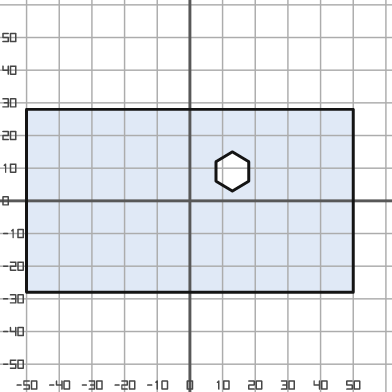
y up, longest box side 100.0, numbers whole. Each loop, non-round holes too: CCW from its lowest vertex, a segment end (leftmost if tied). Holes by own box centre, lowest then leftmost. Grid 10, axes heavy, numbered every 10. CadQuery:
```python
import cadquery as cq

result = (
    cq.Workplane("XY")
    .moveTo(-50.0, -28.0)
    .lineTo(50.0, -28.0)
    .lineTo(50.0, 28.0)
    .lineTo(-50.0, 28.0)
    .close()
    .moveTo(13.0, 3.0)
    .lineTo(18.0, 6.0)
    .lineTo(18.0, 12.0)
    .lineTo(13.0, 15.0)
    .lineTo(8.0, 12.0)
    .lineTo(8.0, 6.0)
    .close()
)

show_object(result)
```